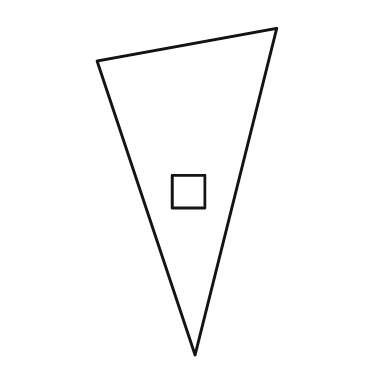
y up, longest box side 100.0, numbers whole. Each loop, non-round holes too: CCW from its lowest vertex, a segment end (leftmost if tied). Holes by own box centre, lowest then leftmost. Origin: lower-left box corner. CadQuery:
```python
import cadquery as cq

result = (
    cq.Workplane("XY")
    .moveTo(30.0, 0.0)
    .lineTo(55.0, 100.0)
    .lineTo(0.0, 90.0)
    .close()
    .moveTo(23.0, 45.0)
    .lineTo(33.0, 45.0)
    .lineTo(33.0, 55.0)
    .lineTo(23.0, 55.0)
    .close()
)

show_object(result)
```